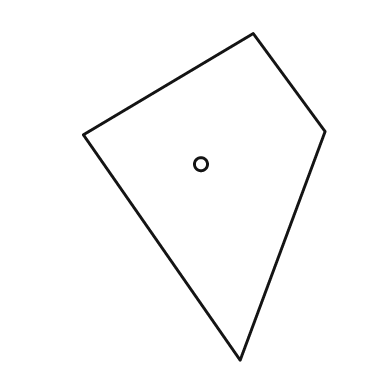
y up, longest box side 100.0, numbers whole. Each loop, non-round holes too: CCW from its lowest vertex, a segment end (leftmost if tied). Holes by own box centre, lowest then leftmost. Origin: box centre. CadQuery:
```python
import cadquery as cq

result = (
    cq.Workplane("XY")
    .moveTo(11.0, -50.0)
    .lineTo(37.0, 20.0)
    .lineTo(15.0, 50.0)
    .lineTo(-37.0, 19.0)
    .close()
    .moveTo(-1.0, 10.0)
    .circle(2.0)
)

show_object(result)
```